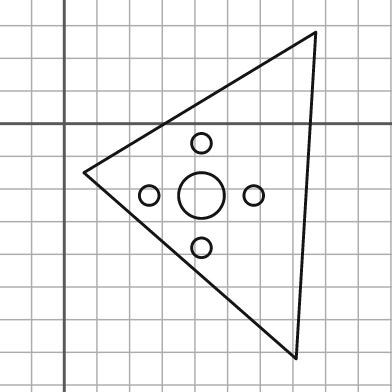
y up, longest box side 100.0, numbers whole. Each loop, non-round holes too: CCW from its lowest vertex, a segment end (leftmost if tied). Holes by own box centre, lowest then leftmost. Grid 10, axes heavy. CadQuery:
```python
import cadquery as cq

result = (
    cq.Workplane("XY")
    .moveTo(71.0, -72.0)
    .lineTo(77.0, 28.0)
    .lineTo(6.0, -15.0)
    .close()
    .moveTo(42.0, -38.0)
    .circle(3.0)
    .moveTo(26.0, -22.0)
    .circle(3.0)
    .moveTo(42.0, -22.0)
    .circle(7.0)
    .moveTo(58.0, -22.0)
    .circle(3.0)
    .moveTo(42.0, -6.0)
    .circle(3.0)
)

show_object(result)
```